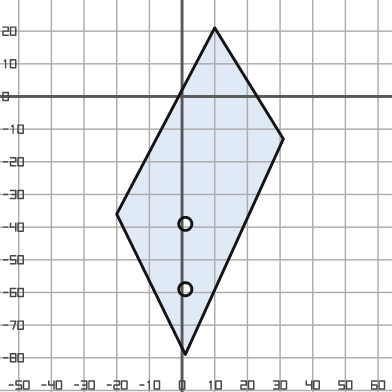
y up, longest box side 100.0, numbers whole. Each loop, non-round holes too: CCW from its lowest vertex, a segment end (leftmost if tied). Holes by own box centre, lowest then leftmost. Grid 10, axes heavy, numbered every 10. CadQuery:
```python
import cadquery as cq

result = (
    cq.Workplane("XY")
    .moveTo(1.0, -79.0)
    .lineTo(31.0, -13.0)
    .lineTo(10.0, 21.0)
    .lineTo(-20.0, -36.0)
    .close()
    .moveTo(1.0, -59.0)
    .circle(2.0)
    .moveTo(1.0, -39.0)
    .circle(2.0)
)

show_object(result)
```